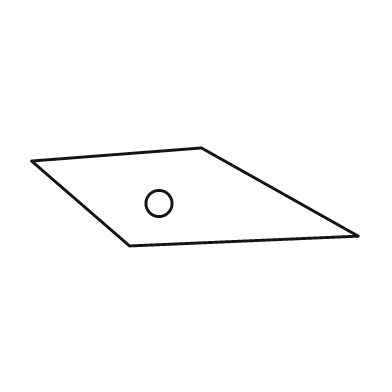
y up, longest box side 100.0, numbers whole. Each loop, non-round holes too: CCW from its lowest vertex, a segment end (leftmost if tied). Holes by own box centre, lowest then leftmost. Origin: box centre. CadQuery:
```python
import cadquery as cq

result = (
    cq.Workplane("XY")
    .moveTo(-20.0, -15.0)
    .lineTo(50.0, -12.0)
    .lineTo(2.0, 15.0)
    .lineTo(-50.0, 11.0)
    .close()
    .moveTo(-11.0, -2.0)
    .circle(4.0)
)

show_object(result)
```